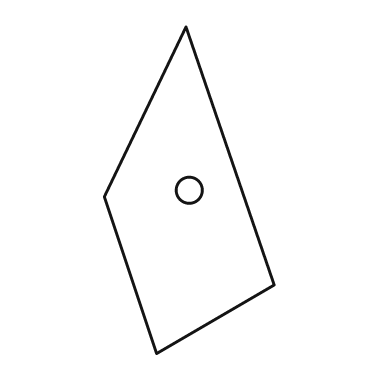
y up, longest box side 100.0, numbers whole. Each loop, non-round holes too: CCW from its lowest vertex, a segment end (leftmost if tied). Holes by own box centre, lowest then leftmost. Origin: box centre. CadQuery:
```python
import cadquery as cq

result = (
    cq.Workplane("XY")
    .moveTo(-10.0, -50.0)
    .lineTo(26.0, -29.0)
    .lineTo(-1.0, 50.0)
    .lineTo(-26.0, -2.0)
    .close()
    .moveTo(0.0, 0.0)
    .circle(4.0)
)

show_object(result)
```